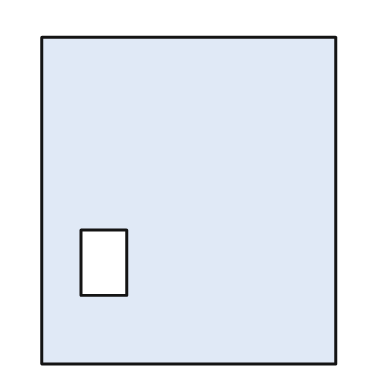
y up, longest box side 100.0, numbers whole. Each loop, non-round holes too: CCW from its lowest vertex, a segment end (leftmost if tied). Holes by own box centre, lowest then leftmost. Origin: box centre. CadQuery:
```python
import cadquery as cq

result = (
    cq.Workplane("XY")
    .moveTo(-45.0, -50.0)
    .lineTo(45.0, -50.0)
    .lineTo(45.0, 50.0)
    .lineTo(-45.0, 50.0)
    .close()
    .moveTo(-33.0, -29.0)
    .lineTo(-19.0, -29.0)
    .lineTo(-19.0, -9.0)
    .lineTo(-33.0, -9.0)
    .close()
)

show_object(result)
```